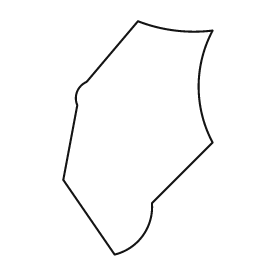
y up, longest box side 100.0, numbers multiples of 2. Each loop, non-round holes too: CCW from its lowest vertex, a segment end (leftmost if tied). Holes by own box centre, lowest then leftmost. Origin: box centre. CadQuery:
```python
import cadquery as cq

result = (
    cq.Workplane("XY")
    .moveTo(-10.0, -50.0)
    .threePointArc((2.0, -42.0), (6.0, -28.0))
    .lineTo(32.0, -2.0)
    .threePointArc((26.0, 22.0), (32.0, 46.0))
    .threePointArc((16.0, 46.0), (0.0, 50.0))
    .lineTo(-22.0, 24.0)
    .threePointArc((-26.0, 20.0), (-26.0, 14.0))
    .lineTo(-32.0, -18.0)
    .close()
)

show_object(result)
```